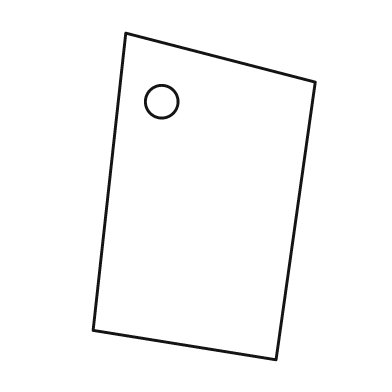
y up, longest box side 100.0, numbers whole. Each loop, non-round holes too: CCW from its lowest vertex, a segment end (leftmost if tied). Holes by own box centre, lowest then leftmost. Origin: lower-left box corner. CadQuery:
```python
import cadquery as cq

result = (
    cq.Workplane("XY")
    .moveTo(56.0, 0.0)
    .lineTo(68.0, 85.0)
    .lineTo(10.0, 100.0)
    .lineTo(0.0, 9.0)
    .close()
    .moveTo(21.0, 79.0)
    .circle(5.0)
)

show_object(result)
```